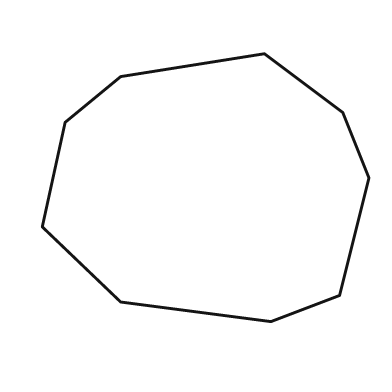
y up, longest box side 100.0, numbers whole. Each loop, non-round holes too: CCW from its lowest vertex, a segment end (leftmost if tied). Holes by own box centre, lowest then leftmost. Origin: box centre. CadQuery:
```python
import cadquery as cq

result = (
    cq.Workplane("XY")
    .moveTo(20.0, -41.0)
    .lineTo(41.0, -33.0)
    .lineTo(50.0, 3.0)
    .lineTo(42.0, 23.0)
    .lineTo(18.0, 41.0)
    .lineTo(-26.0, 34.0)
    .lineTo(-43.0, 20.0)
    .lineTo(-50.0, -12.0)
    .lineTo(-26.0, -35.0)
    .close()
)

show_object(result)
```